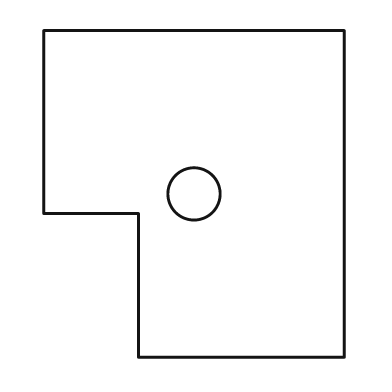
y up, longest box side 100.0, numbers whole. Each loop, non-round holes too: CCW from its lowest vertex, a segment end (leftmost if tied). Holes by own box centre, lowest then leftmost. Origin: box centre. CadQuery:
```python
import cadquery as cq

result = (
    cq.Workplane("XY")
    .moveTo(-17.0, -50.0)
    .lineTo(46.0, -50.0)
    .lineTo(46.0, 50.0)
    .lineTo(-46.0, 50.0)
    .lineTo(-46.0, -6.0)
    .lineTo(-17.0, -6.0)
    .close()
    .moveTo(0.0, 0.0)
    .circle(8.0)
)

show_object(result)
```